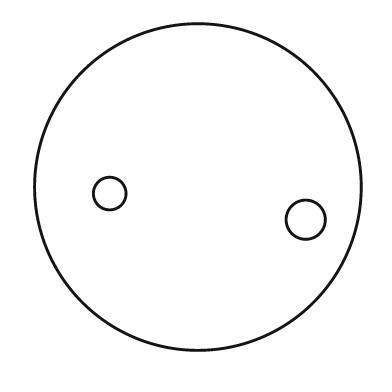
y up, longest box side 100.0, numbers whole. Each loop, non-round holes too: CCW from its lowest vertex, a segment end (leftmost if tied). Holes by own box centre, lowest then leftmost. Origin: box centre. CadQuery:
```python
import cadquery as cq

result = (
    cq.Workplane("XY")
    .moveTo(0.0, 0.0)
    .circle(50.0)
    .moveTo(33.0, -10.0)
    .circle(6.0)
    .moveTo(-27.0, -2.0)
    .circle(5.0)
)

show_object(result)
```